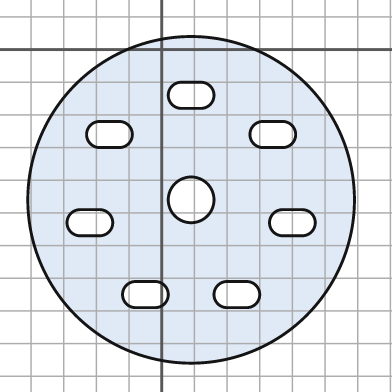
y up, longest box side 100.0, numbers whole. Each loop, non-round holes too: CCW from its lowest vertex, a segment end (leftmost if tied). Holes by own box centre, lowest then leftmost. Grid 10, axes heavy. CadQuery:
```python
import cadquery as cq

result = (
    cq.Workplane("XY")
    .moveTo(9.0, -46.0)
    .circle(50.0)
    .moveTo(-8.0, -79.0)
    .lineTo(-2.0, -79.0)
    .threePointArc((2.0, -75.0), (-2.0, -71.0))
    .lineTo(-8.0, -71.0)
    .threePointArc((-12.0, -75.0), (-8.0, -79.0))
    .close()
    .moveTo(20.0, -79.0)
    .lineTo(26.0, -79.0)
    .threePointArc((30.0, -75.0), (26.0, -71.0))
    .lineTo(20.0, -71.0)
    .threePointArc((16.0, -75.0), (20.0, -79.0))
    .close()
    .moveTo(-25.0, -57.0)
    .lineTo(-19.0, -57.0)
    .threePointArc((-15.0, -53.0), (-19.0, -49.0))
    .lineTo(-25.0, -49.0)
    .threePointArc((-29.0, -53.0), (-25.0, -57.0))
    .close()
    .moveTo(37.0, -57.0)
    .lineTo(43.0, -57.0)
    .threePointArc((47.0, -53.0), (43.0, -49.0))
    .lineTo(37.0, -49.0)
    .threePointArc((33.0, -53.0), (37.0, -57.0))
    .close()
    .moveTo(9.0, -46.0)
    .circle(7.0)
    .moveTo(-19.0, -30.0)
    .lineTo(-13.0, -30.0)
    .threePointArc((-9.0, -26.0), (-13.0, -22.0))
    .lineTo(-19.0, -22.0)
    .threePointArc((-23.0, -26.0), (-19.0, -30.0))
    .close()
    .moveTo(31.0, -30.0)
    .lineTo(37.0, -30.0)
    .threePointArc((41.0, -26.0), (37.0, -22.0))
    .lineTo(31.0, -22.0)
    .threePointArc((27.0, -26.0), (31.0, -30.0))
    .close()
    .moveTo(6.0, -18.0)
    .lineTo(12.0, -18.0)
    .threePointArc((16.0, -14.0), (12.0, -10.0))
    .lineTo(6.0, -10.0)
    .threePointArc((2.0, -14.0), (6.0, -18.0))
    .close()
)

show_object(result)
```